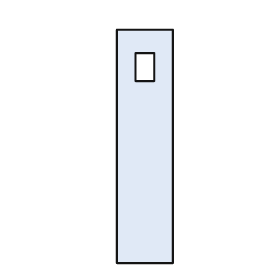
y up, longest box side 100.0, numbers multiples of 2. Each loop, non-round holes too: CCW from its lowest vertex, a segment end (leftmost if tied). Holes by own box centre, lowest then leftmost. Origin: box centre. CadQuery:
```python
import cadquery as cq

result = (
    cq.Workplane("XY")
    .moveTo(-12.0, -50.0)
    .lineTo(12.0, -50.0)
    .lineTo(12.0, 50.0)
    .lineTo(-12.0, 50.0)
    .close()
    .moveTo(-4.0, 28.0)
    .lineTo(4.0, 28.0)
    .lineTo(4.0, 40.0)
    .lineTo(-4.0, 40.0)
    .close()
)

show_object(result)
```